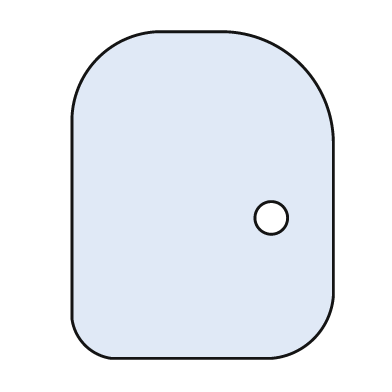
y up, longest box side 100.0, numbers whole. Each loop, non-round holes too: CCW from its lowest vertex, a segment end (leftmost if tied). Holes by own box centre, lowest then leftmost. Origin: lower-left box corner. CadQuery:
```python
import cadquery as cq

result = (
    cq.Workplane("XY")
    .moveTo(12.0, 0.0)
    .lineTo(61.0, 0.0)
    .threePointArc((74.0, 6.0), (80.0, 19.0))
    .lineTo(80.0, 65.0)
    .threePointArc((70.0, 90.0), (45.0, 100.0))
    .lineTo(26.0, 100.0)
    .threePointArc((8.0, 92.0), (0.0, 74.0))
    .lineTo(0.0, 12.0)
    .threePointArc((4.0, 4.0), (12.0, 0.0))
    .close()
    .moveTo(61.0, 43.0)
    .circle(5.0)
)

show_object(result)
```